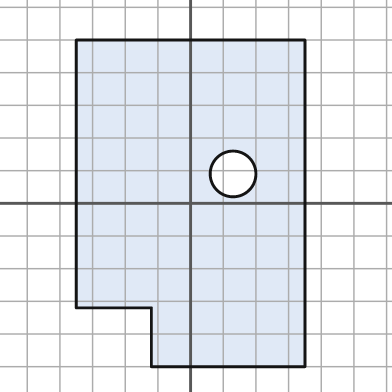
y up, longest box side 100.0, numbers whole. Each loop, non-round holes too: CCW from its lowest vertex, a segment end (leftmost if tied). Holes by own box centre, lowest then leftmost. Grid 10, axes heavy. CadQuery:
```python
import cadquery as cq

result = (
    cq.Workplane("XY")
    .moveTo(-12.0, -50.0)
    .lineTo(35.0, -50.0)
    .lineTo(35.0, 50.0)
    .lineTo(-35.0, 50.0)
    .lineTo(-35.0, -32.0)
    .lineTo(-12.0, -32.0)
    .close()
    .moveTo(13.0, 9.0)
    .circle(7.0)
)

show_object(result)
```